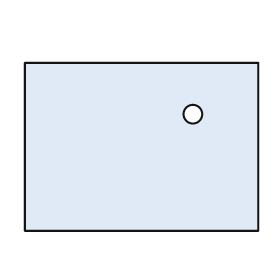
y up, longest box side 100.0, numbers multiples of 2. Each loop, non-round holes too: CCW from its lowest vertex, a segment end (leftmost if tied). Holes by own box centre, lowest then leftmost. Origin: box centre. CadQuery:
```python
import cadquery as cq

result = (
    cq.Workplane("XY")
    .moveTo(-50.0, -36.0)
    .lineTo(50.0, -36.0)
    .lineTo(50.0, 36.0)
    .lineTo(-50.0, 36.0)
    .close()
    .moveTo(22.0, 14.0)
    .circle(4.0)
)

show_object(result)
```